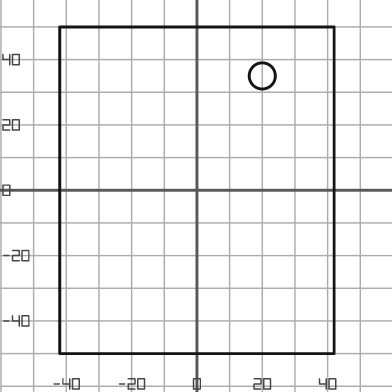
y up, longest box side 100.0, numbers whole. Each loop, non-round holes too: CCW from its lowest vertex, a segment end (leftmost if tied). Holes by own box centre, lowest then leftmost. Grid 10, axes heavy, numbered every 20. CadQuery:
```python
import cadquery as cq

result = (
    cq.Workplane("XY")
    .moveTo(-42.0, -50.0)
    .lineTo(42.0, -50.0)
    .lineTo(42.0, 50.0)
    .lineTo(-42.0, 50.0)
    .close()
    .moveTo(20.0, 35.0)
    .circle(4.0)
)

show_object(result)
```